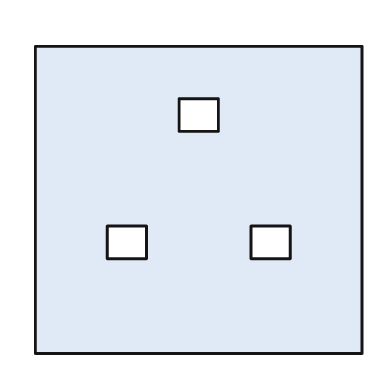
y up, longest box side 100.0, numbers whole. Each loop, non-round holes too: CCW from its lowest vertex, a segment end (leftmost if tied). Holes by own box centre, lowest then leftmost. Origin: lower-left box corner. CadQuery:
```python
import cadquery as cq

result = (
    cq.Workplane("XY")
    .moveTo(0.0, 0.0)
    .lineTo(100.0, 0.0)
    .lineTo(100.0, 94.0)
    .lineTo(0.0, 94.0)
    .close()
    .moveTo(22.0, 29.0)
    .lineTo(34.0, 29.0)
    .lineTo(34.0, 39.0)
    .lineTo(22.0, 39.0)
    .close()
    .moveTo(66.0, 29.0)
    .lineTo(78.0, 29.0)
    .lineTo(78.0, 39.0)
    .lineTo(66.0, 39.0)
    .close()
    .moveTo(44.0, 68.0)
    .lineTo(56.0, 68.0)
    .lineTo(56.0, 78.0)
    .lineTo(44.0, 78.0)
    .close()
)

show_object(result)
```